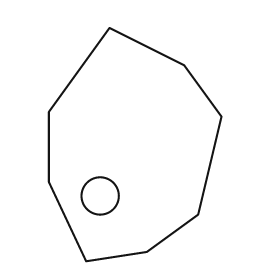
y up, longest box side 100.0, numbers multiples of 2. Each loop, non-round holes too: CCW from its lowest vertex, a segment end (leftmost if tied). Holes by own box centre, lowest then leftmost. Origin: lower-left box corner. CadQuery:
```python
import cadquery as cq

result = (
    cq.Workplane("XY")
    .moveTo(16.0, 0.0)
    .lineTo(42.0, 4.0)
    .lineTo(64.0, 20.0)
    .lineTo(74.0, 62.0)
    .lineTo(58.0, 84.0)
    .lineTo(26.0, 100.0)
    .lineTo(0.0, 64.0)
    .lineTo(0.0, 34.0)
    .close()
    .moveTo(22.0, 28.0)
    .circle(8.0)
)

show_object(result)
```